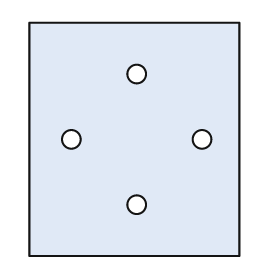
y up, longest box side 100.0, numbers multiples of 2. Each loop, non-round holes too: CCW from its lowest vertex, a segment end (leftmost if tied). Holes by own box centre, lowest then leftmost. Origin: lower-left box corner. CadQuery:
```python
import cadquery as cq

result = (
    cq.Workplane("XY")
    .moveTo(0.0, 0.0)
    .lineTo(90.0, 0.0)
    .lineTo(90.0, 100.0)
    .lineTo(0.0, 100.0)
    .close()
    .moveTo(46.0, 22.0)
    .circle(4.0)
    .moveTo(18.0, 50.0)
    .circle(4.0)
    .moveTo(74.0, 50.0)
    .circle(4.0)
    .moveTo(46.0, 78.0)
    .circle(4.0)
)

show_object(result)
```